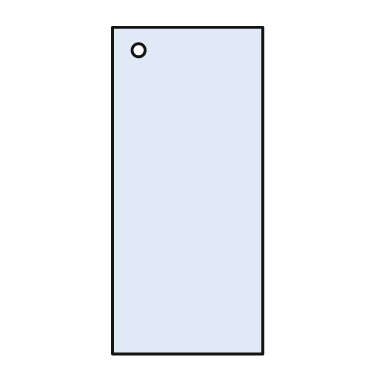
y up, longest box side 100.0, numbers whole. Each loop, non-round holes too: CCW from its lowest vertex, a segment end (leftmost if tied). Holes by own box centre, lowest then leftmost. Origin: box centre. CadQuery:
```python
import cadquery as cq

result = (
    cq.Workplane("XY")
    .moveTo(-23.0, -50.0)
    .lineTo(23.0, -50.0)
    .lineTo(23.0, 50.0)
    .lineTo(-23.0, 50.0)
    .close()
    .moveTo(-15.0, 43.0)
    .circle(2.0)
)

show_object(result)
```